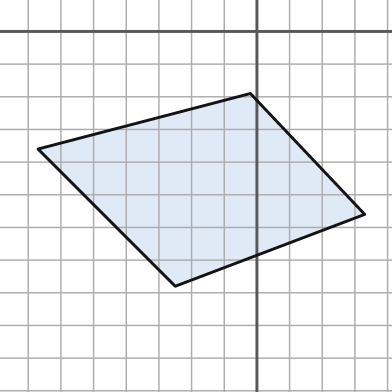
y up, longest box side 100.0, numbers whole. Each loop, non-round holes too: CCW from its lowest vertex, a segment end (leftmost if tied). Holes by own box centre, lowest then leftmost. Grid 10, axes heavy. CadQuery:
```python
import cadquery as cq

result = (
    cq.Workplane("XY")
    .moveTo(-25.0, -78.0)
    .lineTo(33.0, -56.0)
    .lineTo(-2.0, -19.0)
    .lineTo(-67.0, -36.0)
    .close()
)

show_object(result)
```